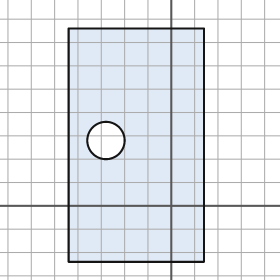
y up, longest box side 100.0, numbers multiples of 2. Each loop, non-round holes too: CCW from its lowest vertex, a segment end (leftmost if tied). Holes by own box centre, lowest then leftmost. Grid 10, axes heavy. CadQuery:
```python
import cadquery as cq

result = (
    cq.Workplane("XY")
    .moveTo(-44.0, -24.0)
    .lineTo(14.0, -24.0)
    .lineTo(14.0, 76.0)
    .lineTo(-44.0, 76.0)
    .close()
    .moveTo(-28.0, 28.0)
    .circle(8.0)
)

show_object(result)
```